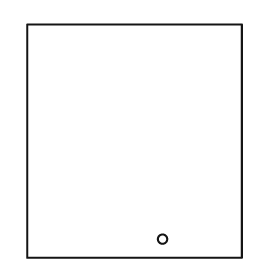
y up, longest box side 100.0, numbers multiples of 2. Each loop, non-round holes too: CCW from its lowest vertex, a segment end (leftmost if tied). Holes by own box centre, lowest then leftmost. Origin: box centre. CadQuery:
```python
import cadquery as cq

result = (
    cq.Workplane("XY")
    .moveTo(-46.0, -50.0)
    .lineTo(46.0, -50.0)
    .lineTo(46.0, 50.0)
    .lineTo(-46.0, 50.0)
    .close()
    .moveTo(12.0, -42.0)
    .circle(2.0)
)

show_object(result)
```